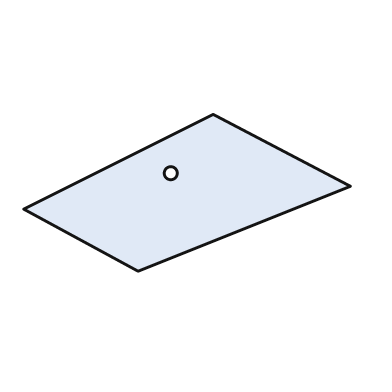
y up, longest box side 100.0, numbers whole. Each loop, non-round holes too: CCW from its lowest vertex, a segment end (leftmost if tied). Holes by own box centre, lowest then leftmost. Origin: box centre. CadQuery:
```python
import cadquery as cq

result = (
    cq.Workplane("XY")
    .moveTo(-15.0, -24.0)
    .lineTo(50.0, 2.0)
    .lineTo(8.0, 24.0)
    .lineTo(-50.0, -5.0)
    .close()
    .moveTo(-5.0, 6.0)
    .circle(2.0)
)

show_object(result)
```